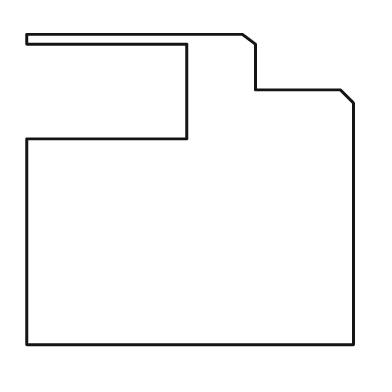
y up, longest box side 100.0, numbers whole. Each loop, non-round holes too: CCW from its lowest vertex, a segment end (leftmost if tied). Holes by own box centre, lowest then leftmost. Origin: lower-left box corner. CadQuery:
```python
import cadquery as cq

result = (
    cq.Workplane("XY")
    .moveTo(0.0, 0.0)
    .lineTo(100.0, 0.0)
    .lineTo(100.0, 74.0)
    .lineTo(96.0, 78.0)
    .lineTo(70.0, 78.0)
    .lineTo(70.0, 92.0)
    .lineTo(66.0, 95.0)
    .lineTo(0.0, 95.0)
    .lineTo(0.0, 92.0)
    .lineTo(49.0, 92.0)
    .lineTo(49.0, 63.0)
    .lineTo(0.0, 63.0)
    .close()
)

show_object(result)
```